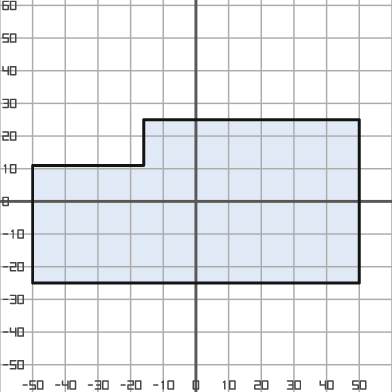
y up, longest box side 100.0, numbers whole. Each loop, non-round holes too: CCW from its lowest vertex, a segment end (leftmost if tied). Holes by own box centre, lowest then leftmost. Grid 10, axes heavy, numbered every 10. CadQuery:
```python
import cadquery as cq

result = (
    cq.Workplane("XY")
    .moveTo(-50.0, -25.0)
    .lineTo(50.0, -25.0)
    .lineTo(50.0, 25.0)
    .lineTo(-16.0, 25.0)
    .lineTo(-16.0, 11.0)
    .lineTo(-50.0, 11.0)
    .close()
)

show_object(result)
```